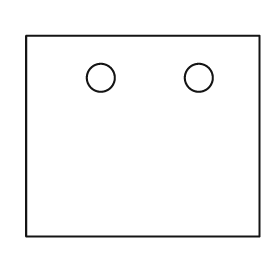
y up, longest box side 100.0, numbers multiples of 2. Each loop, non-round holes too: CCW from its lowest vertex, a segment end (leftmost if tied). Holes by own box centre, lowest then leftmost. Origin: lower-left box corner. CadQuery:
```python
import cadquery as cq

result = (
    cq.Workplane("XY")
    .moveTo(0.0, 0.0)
    .lineTo(100.0, 0.0)
    .lineTo(100.0, 86.0)
    .lineTo(0.0, 86.0)
    .close()
    .moveTo(32.0, 68.0)
    .circle(6.0)
    .moveTo(74.0, 68.0)
    .circle(6.0)
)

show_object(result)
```